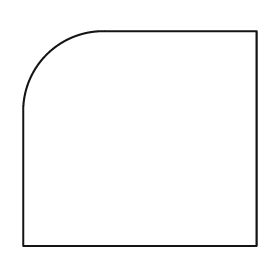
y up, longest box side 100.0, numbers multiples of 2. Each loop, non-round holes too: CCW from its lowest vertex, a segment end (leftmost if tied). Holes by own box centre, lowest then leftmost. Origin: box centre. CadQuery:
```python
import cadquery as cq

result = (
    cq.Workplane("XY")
    .moveTo(-50.0, -46.0)
    .lineTo(50.0, -46.0)
    .lineTo(50.0, 46.0)
    .lineTo(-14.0, 46.0)
    .threePointArc((-40.0, 36.0), (-50.0, 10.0))
    .close()
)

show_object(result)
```